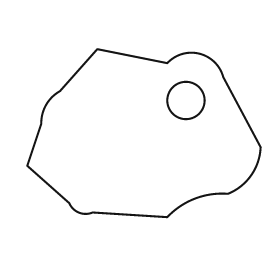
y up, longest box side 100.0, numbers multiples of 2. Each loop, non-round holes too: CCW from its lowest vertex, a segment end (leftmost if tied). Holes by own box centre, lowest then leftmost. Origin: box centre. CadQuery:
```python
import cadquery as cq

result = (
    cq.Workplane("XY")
    .moveTo(10.0, -36.0)
    .threePointArc((22.0, -28.0), (36.0, -26.0))
    .threePointArc((46.0, -18.0), (50.0, -6.0))
    .lineTo(34.0, 24.0)
    .threePointArc((24.0, 34.0), (10.0, 30.0))
    .lineTo(-20.0, 36.0)
    .lineTo(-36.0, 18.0)
    .threePointArc((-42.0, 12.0), (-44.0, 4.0))
    .lineTo(-50.0, -14.0)
    .lineTo(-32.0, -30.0)
    .threePointArc((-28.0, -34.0), (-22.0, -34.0))
    .close()
    .moveTo(18.0, 14.0)
    .circle(8.0)
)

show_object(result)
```